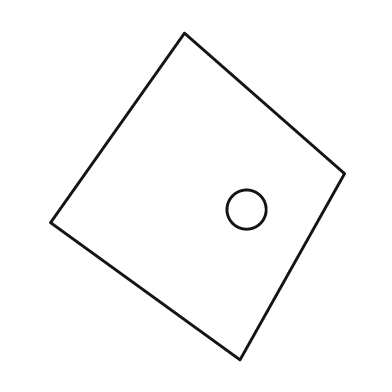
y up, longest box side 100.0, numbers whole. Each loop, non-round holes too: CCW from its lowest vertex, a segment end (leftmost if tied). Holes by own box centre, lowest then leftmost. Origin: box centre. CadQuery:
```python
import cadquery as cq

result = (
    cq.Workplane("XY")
    .moveTo(13.0, -50.0)
    .lineTo(45.0, 7.0)
    .lineTo(-4.0, 50.0)
    .lineTo(-45.0, -8.0)
    .close()
    .moveTo(15.0, -4.0)
    .circle(6.0)
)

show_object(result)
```